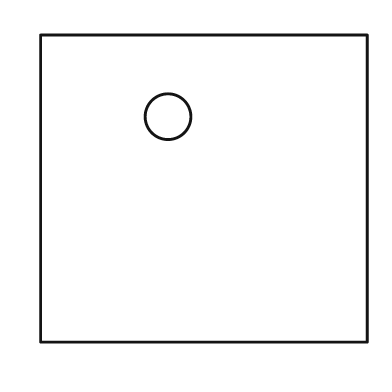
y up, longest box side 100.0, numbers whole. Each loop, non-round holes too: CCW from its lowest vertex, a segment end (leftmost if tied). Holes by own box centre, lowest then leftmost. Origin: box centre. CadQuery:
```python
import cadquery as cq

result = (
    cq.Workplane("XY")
    .moveTo(-50.0, -47.0)
    .lineTo(50.0, -47.0)
    .lineTo(50.0, 47.0)
    .lineTo(-50.0, 47.0)
    .close()
    .moveTo(-11.0, 22.0)
    .circle(7.0)
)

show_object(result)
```